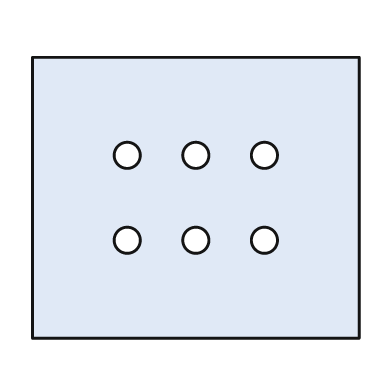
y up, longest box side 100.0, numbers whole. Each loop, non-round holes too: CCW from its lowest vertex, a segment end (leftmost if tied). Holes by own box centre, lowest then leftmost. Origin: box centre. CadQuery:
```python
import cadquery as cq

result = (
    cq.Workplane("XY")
    .moveTo(-50.0, -43.0)
    .lineTo(50.0, -43.0)
    .lineTo(50.0, 43.0)
    .lineTo(-50.0, 43.0)
    .close()
    .moveTo(-21.0, -13.0)
    .circle(4.0)
    .moveTo(0.0, -13.0)
    .circle(4.0)
    .moveTo(21.0, -13.0)
    .circle(4.0)
    .moveTo(-21.0, 13.0)
    .circle(4.0)
    .moveTo(0.0, 13.0)
    .circle(4.0)
    .moveTo(21.0, 13.0)
    .circle(4.0)
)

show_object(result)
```